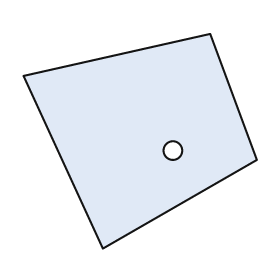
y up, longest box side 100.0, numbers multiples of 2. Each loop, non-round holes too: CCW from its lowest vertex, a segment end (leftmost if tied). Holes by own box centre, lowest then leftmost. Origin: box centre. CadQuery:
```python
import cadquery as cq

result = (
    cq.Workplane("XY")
    .moveTo(-16.0, -46.0)
    .lineTo(50.0, -8.0)
    .lineTo(30.0, 46.0)
    .lineTo(-50.0, 28.0)
    .close()
    .moveTo(14.0, -4.0)
    .circle(4.0)
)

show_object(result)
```